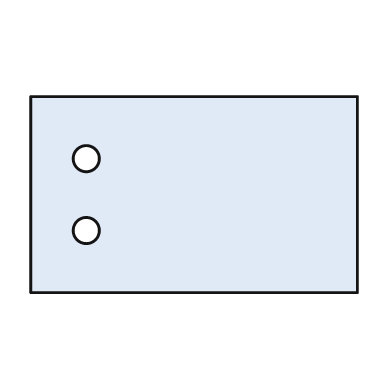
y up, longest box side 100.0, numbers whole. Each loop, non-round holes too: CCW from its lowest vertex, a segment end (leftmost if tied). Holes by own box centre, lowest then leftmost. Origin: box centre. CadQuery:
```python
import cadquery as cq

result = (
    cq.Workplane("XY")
    .moveTo(-50.0, -30.0)
    .lineTo(50.0, -30.0)
    .lineTo(50.0, 30.0)
    .lineTo(-50.0, 30.0)
    .close()
    .moveTo(-33.0, -11.0)
    .circle(4.0)
    .moveTo(-33.0, 11.0)
    .circle(4.0)
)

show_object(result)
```